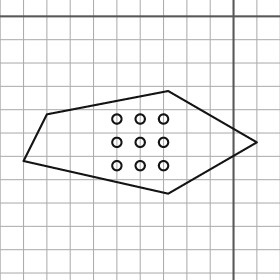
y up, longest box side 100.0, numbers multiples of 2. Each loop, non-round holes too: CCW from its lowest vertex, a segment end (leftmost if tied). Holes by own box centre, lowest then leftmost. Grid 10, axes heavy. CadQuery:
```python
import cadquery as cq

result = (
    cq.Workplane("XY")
    .moveTo(-28.0, -76.0)
    .lineTo(10.0, -54.0)
    .lineTo(-28.0, -32.0)
    .lineTo(-80.0, -42.0)
    .lineTo(-90.0, -62.0)
    .close()
    .moveTo(-50.0, -64.0)
    .circle(2.0)
    .moveTo(-40.0, -64.0)
    .circle(2.0)
    .moveTo(-30.0, -64.0)
    .circle(2.0)
    .moveTo(-50.0, -54.0)
    .circle(2.0)
    .moveTo(-40.0, -54.0)
    .circle(2.0)
    .moveTo(-30.0, -54.0)
    .circle(2.0)
    .moveTo(-50.0, -44.0)
    .circle(2.0)
    .moveTo(-40.0, -44.0)
    .circle(2.0)
    .moveTo(-30.0, -44.0)
    .circle(2.0)
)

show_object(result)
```